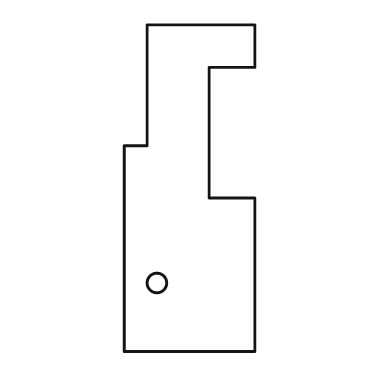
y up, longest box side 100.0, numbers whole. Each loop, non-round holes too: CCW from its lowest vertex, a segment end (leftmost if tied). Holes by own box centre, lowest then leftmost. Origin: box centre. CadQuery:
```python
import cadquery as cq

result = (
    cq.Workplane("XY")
    .moveTo(-20.0, -50.0)
    .lineTo(20.0, -50.0)
    .lineTo(20.0, -3.0)
    .lineTo(6.0, -3.0)
    .lineTo(6.0, 37.0)
    .lineTo(20.0, 37.0)
    .lineTo(20.0, 50.0)
    .lineTo(-13.0, 50.0)
    .lineTo(-13.0, 13.0)
    .lineTo(-20.0, 13.0)
    .close()
    .moveTo(-10.0, -29.0)
    .circle(3.0)
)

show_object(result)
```